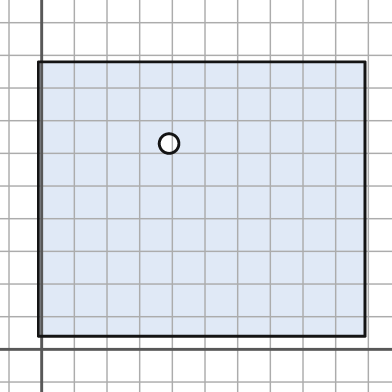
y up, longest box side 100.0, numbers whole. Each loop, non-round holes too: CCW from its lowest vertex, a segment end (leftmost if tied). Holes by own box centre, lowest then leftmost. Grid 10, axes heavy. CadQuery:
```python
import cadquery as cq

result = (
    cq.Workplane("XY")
    .moveTo(-1.0, 4.0)
    .lineTo(99.0, 4.0)
    .lineTo(99.0, 88.0)
    .lineTo(-1.0, 88.0)
    .close()
    .moveTo(39.0, 63.0)
    .circle(3.0)
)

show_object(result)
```